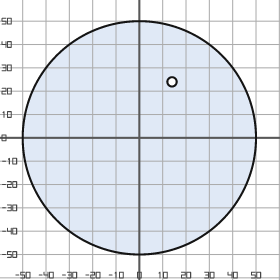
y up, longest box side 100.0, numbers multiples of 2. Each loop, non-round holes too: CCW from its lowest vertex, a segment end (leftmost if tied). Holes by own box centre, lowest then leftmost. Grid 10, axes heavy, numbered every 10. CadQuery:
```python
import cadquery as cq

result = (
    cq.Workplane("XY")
    .moveTo(0.0, 0.0)
    .circle(50.0)
    .moveTo(14.0, 24.0)
    .circle(2.0)
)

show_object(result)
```